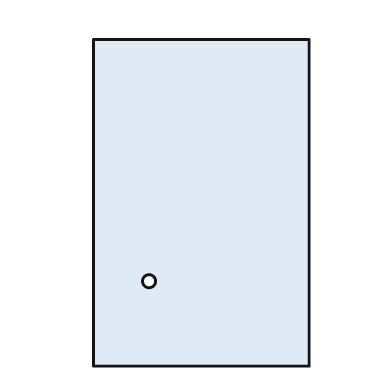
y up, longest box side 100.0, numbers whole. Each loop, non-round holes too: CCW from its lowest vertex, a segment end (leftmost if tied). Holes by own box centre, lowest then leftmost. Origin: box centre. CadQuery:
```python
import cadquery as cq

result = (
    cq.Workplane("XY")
    .moveTo(-33.0, -50.0)
    .lineTo(33.0, -50.0)
    .lineTo(33.0, 50.0)
    .lineTo(-33.0, 50.0)
    .close()
    .moveTo(-16.0, -24.0)
    .circle(2.0)
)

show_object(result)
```